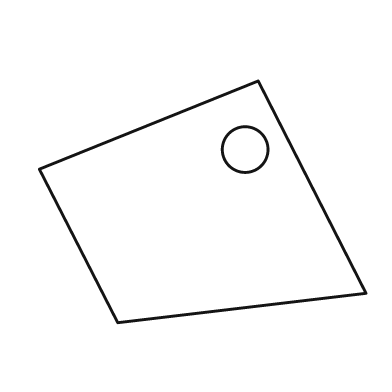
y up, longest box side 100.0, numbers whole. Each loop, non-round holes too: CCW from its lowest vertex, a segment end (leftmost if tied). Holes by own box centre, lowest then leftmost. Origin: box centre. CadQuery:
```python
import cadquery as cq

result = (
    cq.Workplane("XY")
    .moveTo(-26.0, -37.0)
    .lineTo(50.0, -28.0)
    .lineTo(17.0, 37.0)
    .lineTo(-50.0, 10.0)
    .close()
    .moveTo(13.0, 16.0)
    .circle(7.0)
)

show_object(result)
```